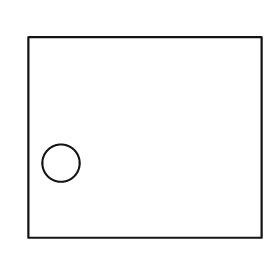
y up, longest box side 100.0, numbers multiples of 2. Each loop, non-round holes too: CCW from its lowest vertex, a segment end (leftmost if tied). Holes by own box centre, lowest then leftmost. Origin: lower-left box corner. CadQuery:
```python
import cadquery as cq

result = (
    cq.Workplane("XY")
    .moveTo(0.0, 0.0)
    .lineTo(100.0, 0.0)
    .lineTo(100.0, 86.0)
    .lineTo(0.0, 86.0)
    .close()
    .moveTo(14.0, 32.0)
    .circle(8.0)
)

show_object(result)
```